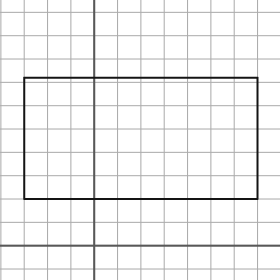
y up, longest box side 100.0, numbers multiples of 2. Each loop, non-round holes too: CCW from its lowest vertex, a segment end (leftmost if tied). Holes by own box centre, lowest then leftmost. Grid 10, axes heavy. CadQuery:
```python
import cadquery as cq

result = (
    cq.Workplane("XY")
    .moveTo(-30.0, 20.0)
    .lineTo(70.0, 20.0)
    .lineTo(70.0, 72.0)
    .lineTo(-30.0, 72.0)
    .close()
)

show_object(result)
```